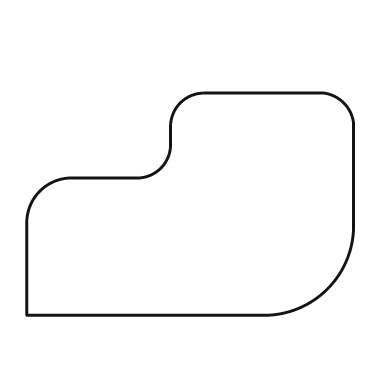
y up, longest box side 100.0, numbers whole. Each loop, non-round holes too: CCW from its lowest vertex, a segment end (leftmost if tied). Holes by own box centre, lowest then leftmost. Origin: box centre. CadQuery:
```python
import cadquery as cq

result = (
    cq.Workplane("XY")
    .moveTo(-50.0, -34.0)
    .lineTo(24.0, -34.0)
    .threePointArc((42.0, -26.0), (50.0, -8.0))
    .lineTo(50.0, 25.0)
    .threePointArc((47.0, 31.0), (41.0, 34.0))
    .lineTo(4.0, 34.0)
    .threePointArc((-3.0, 31.0), (-6.0, 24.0))
    .lineTo(-6.0, 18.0)
    .threePointArc((-9.0, 11.0), (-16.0, 8.0))
    .lineTo(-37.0, 8.0)
    .threePointArc((-46.0, 4.0), (-50.0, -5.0))
    .close()
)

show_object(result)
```